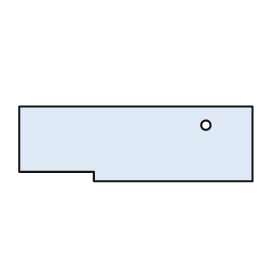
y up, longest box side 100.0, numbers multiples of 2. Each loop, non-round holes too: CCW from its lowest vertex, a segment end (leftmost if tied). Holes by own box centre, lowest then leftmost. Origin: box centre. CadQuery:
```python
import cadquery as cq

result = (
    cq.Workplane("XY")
    .moveTo(-18.0, -16.0)
    .lineTo(50.0, -16.0)
    .lineTo(50.0, 16.0)
    .lineTo(-50.0, 16.0)
    .lineTo(-50.0, -12.0)
    .lineTo(-18.0, -12.0)
    .close()
    .moveTo(30.0, 8.0)
    .circle(2.0)
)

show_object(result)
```